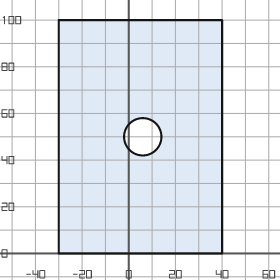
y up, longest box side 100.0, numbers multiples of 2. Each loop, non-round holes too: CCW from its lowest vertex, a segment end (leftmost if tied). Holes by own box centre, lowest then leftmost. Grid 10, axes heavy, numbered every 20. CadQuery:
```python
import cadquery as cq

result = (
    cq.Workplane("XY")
    .moveTo(-30.0, 0.0)
    .lineTo(40.0, 0.0)
    .lineTo(40.0, 100.0)
    .lineTo(-30.0, 100.0)
    .close()
    .moveTo(6.0, 50.0)
    .circle(8.0)
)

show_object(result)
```